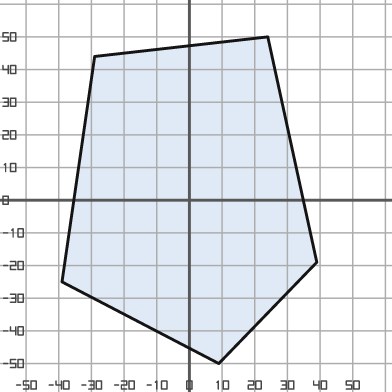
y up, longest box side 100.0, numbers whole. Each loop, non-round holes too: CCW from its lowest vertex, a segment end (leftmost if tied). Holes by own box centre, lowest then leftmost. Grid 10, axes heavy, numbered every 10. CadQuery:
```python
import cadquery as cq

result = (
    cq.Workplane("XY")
    .moveTo(9.0, -50.0)
    .lineTo(39.0, -19.0)
    .lineTo(24.0, 50.0)
    .lineTo(-29.0, 44.0)
    .lineTo(-39.0, -25.0)
    .close()
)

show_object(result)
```